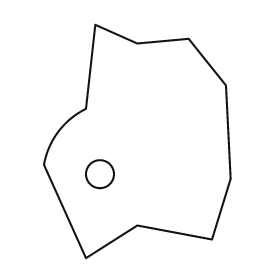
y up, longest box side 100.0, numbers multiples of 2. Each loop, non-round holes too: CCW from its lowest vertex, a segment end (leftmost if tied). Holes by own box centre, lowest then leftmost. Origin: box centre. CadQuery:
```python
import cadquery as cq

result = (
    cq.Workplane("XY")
    .moveTo(-22.0, -50.0)
    .lineTo(0.0, -36.0)
    .lineTo(32.0, -42.0)
    .lineTo(40.0, -16.0)
    .lineTo(38.0, 24.0)
    .lineTo(22.0, 44.0)
    .lineTo(0.0, 42.0)
    .lineTo(-18.0, 50.0)
    .lineTo(-22.0, 14.0)
    .threePointArc((-34.0, 4.0), (-40.0, -10.0))
    .close()
    .moveTo(-16.0, -14.0)
    .circle(6.0)
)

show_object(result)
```